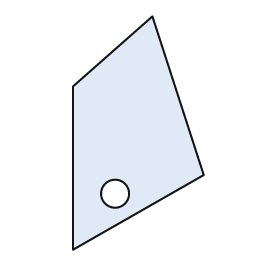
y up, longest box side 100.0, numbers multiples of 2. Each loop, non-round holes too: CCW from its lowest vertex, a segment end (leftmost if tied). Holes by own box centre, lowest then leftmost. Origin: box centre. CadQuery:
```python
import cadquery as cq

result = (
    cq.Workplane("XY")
    .moveTo(-28.0, -50.0)
    .lineTo(28.0, -18.0)
    .lineTo(6.0, 50.0)
    .lineTo(-28.0, 20.0)
    .close()
    .moveTo(-10.0, -26.0)
    .circle(6.0)
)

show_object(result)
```